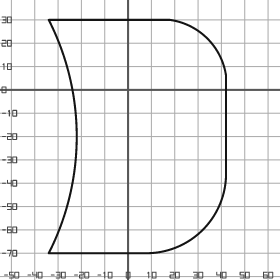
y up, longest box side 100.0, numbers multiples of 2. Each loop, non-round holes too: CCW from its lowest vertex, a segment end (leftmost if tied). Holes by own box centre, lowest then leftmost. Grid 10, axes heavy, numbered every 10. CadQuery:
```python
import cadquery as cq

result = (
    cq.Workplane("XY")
    .moveTo(-34.0, -70.0)
    .lineTo(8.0, -70.0)
    .threePointArc((32.0, -60.0), (42.0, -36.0))
    .lineTo(42.0, 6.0)
    .threePointArc((34.0, 22.0), (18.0, 30.0))
    .lineTo(-34.0, 30.0)
    .threePointArc((-22.0, -20.0), (-34.0, -70.0))
    .close()
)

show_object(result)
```